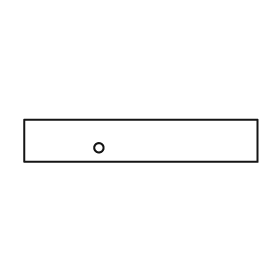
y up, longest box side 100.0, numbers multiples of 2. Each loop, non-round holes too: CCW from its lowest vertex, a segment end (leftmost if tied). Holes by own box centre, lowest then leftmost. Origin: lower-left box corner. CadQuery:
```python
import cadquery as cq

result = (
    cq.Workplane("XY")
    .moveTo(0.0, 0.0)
    .lineTo(100.0, 0.0)
    .lineTo(100.0, 18.0)
    .lineTo(0.0, 18.0)
    .close()
    .moveTo(32.0, 6.0)
    .circle(2.0)
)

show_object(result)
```